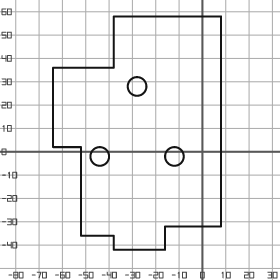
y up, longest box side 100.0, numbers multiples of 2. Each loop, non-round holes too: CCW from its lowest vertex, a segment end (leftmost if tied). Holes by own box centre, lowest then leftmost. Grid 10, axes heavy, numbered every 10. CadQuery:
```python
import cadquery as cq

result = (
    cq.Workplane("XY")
    .moveTo(-38.0, -42.0)
    .lineTo(-16.0, -42.0)
    .lineTo(-16.0, -32.0)
    .lineTo(8.0, -32.0)
    .lineTo(8.0, 58.0)
    .lineTo(-38.0, 58.0)
    .lineTo(-38.0, 36.0)
    .lineTo(-64.0, 36.0)
    .lineTo(-64.0, 2.0)
    .lineTo(-52.0, 2.0)
    .lineTo(-52.0, -36.0)
    .lineTo(-38.0, -36.0)
    .close()
    .moveTo(-44.0, -2.0)
    .circle(4.0)
    .moveTo(-12.0, -2.0)
    .circle(4.0)
    .moveTo(-28.0, 28.0)
    .circle(4.0)
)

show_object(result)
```